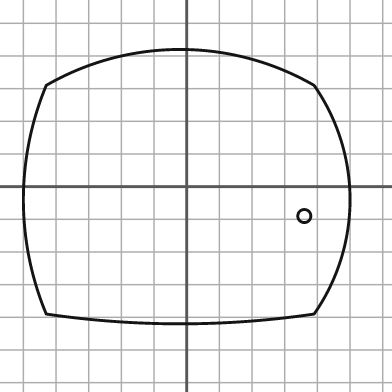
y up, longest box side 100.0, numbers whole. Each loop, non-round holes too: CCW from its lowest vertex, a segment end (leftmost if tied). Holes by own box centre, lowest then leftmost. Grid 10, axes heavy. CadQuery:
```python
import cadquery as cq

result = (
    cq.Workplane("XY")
    .moveTo(-43.0, -39.0)
    .threePointArc((-2.0, -42.0), (39.0, -39.0))
    .threePointArc((50.0, -4.0), (39.0, 31.0))
    .threePointArc((-2.0, 42.0), (-43.0, 31.0))
    .threePointArc((-50.0, -4.0), (-43.0, -39.0))
    .close()
    .moveTo(36.0, -9.0)
    .circle(2.0)
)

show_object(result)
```